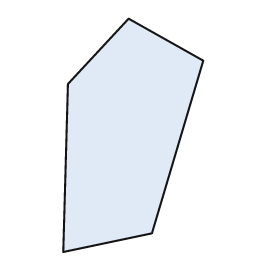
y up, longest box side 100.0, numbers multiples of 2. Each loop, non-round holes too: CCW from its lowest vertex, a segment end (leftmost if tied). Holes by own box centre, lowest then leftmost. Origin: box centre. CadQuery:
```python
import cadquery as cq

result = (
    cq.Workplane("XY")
    .moveTo(-30.0, -50.0)
    .lineTo(8.0, -42.0)
    .lineTo(30.0, 32.0)
    .lineTo(-2.0, 50.0)
    .lineTo(-28.0, 22.0)
    .close()
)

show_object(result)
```